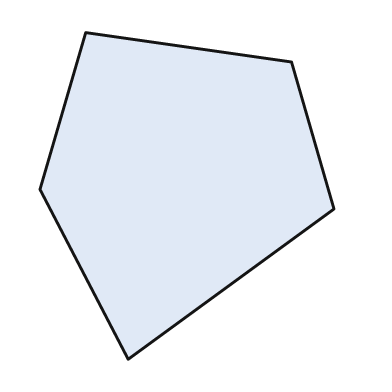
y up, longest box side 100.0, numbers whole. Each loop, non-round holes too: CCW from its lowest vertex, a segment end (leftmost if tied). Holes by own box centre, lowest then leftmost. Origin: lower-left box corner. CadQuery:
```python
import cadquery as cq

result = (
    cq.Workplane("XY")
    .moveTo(27.0, 0.0)
    .lineTo(90.0, 46.0)
    .lineTo(77.0, 91.0)
    .lineTo(14.0, 100.0)
    .lineTo(0.0, 52.0)
    .close()
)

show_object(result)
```